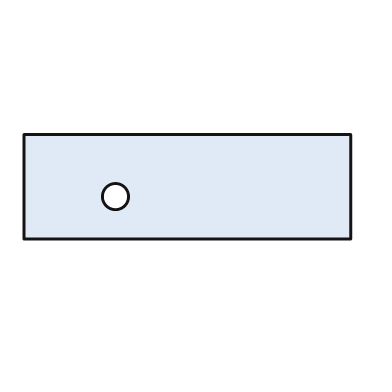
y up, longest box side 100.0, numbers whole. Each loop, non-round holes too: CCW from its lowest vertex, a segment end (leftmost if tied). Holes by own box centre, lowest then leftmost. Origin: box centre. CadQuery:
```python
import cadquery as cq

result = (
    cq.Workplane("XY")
    .moveTo(-50.0, -16.0)
    .lineTo(50.0, -16.0)
    .lineTo(50.0, 16.0)
    .lineTo(-50.0, 16.0)
    .close()
    .moveTo(-22.0, -3.0)
    .circle(4.0)
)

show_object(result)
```